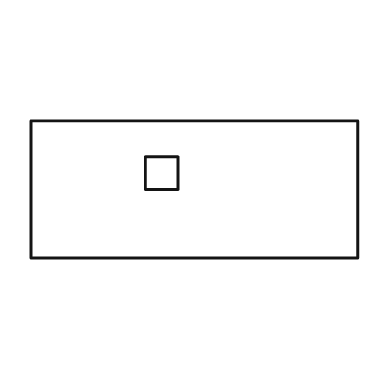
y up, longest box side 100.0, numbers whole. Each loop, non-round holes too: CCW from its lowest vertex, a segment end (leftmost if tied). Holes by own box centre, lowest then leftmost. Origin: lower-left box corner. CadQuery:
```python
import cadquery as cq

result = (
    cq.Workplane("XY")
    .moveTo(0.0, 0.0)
    .lineTo(100.0, 0.0)
    .lineTo(100.0, 42.0)
    .lineTo(0.0, 42.0)
    .close()
    .moveTo(35.0, 21.0)
    .lineTo(45.0, 21.0)
    .lineTo(45.0, 31.0)
    .lineTo(35.0, 31.0)
    .close()
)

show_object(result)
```